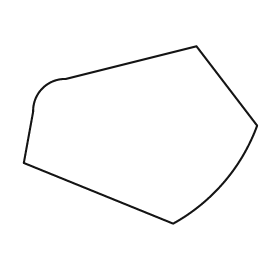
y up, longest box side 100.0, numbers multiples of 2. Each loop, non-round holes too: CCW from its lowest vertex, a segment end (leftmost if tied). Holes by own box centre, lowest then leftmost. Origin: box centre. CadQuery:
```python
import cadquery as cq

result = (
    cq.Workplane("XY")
    .moveTo(14.0, -38.0)
    .threePointArc((36.0, -20.0), (50.0, 4.0))
    .lineTo(24.0, 38.0)
    .lineTo(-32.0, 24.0)
    .threePointArc((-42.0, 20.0), (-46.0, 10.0))
    .lineTo(-50.0, -12.0)
    .close()
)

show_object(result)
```